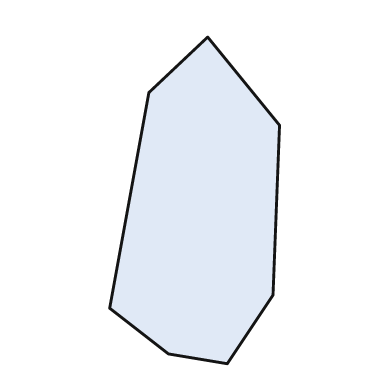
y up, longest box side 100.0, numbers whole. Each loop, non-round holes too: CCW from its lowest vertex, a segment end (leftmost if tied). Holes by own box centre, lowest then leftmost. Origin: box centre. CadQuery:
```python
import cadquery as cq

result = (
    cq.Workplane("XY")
    .moveTo(10.0, -50.0)
    .lineTo(24.0, -29.0)
    .lineTo(26.0, 23.0)
    .lineTo(4.0, 50.0)
    .lineTo(-14.0, 33.0)
    .lineTo(-26.0, -33.0)
    .lineTo(-8.0, -47.0)
    .close()
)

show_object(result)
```